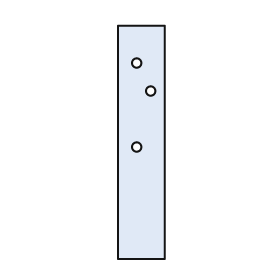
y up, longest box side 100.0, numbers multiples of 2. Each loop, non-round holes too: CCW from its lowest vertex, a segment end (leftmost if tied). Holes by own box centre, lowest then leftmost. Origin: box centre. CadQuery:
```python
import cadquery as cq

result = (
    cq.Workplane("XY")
    .moveTo(-10.0, -50.0)
    .lineTo(10.0, -50.0)
    .lineTo(10.0, 50.0)
    .lineTo(-10.0, 50.0)
    .close()
    .moveTo(-2.0, -2.0)
    .circle(2.0)
    .moveTo(4.0, 22.0)
    .circle(2.0)
    .moveTo(-2.0, 34.0)
    .circle(2.0)
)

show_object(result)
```